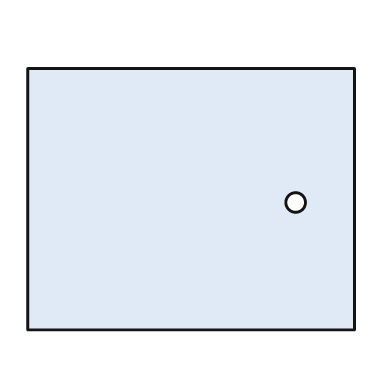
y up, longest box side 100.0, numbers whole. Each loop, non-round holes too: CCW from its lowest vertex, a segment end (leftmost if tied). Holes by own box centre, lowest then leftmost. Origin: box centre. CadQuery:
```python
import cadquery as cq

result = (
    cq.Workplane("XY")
    .moveTo(-50.0, -40.0)
    .lineTo(50.0, -40.0)
    .lineTo(50.0, 40.0)
    .lineTo(-50.0, 40.0)
    .close()
    .moveTo(32.0, -1.0)
    .circle(3.0)
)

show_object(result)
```